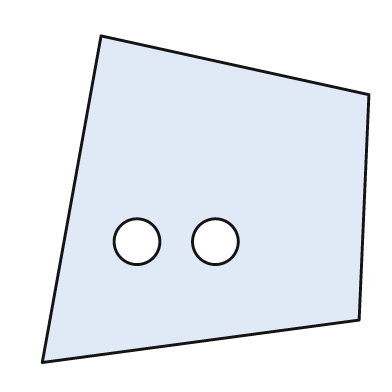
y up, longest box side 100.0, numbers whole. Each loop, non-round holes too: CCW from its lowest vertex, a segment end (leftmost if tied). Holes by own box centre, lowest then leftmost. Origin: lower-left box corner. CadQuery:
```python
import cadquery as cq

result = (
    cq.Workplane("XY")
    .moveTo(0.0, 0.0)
    .lineTo(97.0, 13.0)
    .lineTo(100.0, 82.0)
    .lineTo(18.0, 100.0)
    .close()
    .moveTo(29.0, 37.0)
    .circle(7.0)
    .moveTo(53.0, 37.0)
    .circle(7.0)
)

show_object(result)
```